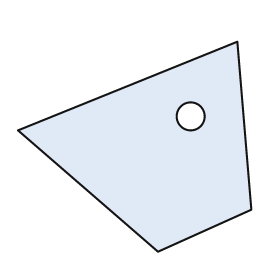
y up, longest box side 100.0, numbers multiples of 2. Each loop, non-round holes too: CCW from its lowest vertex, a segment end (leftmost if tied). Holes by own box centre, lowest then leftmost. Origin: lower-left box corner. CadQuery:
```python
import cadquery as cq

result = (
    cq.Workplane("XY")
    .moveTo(60.0, 0.0)
    .lineTo(100.0, 18.0)
    .lineTo(94.0, 90.0)
    .lineTo(0.0, 52.0)
    .close()
    .moveTo(74.0, 58.0)
    .circle(6.0)
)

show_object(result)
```